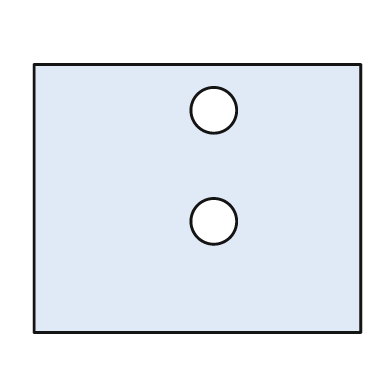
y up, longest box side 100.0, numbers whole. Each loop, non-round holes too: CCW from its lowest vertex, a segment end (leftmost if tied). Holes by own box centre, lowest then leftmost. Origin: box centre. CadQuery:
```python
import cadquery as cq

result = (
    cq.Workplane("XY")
    .moveTo(-50.0, -41.0)
    .lineTo(50.0, -41.0)
    .lineTo(50.0, 41.0)
    .lineTo(-50.0, 41.0)
    .close()
    .moveTo(5.0, -7.0)
    .circle(7.0)
    .moveTo(5.0, 27.0)
    .circle(7.0)
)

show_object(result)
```